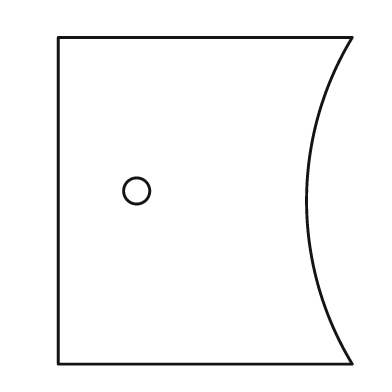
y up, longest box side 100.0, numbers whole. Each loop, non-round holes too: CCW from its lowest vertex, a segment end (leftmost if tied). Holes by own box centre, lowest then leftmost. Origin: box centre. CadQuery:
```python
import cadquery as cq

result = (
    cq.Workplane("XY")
    .moveTo(-45.0, -50.0)
    .lineTo(45.0, -50.0)
    .threePointArc((31.0, 0.0), (45.0, 50.0))
    .lineTo(-45.0, 50.0)
    .close()
    .moveTo(-21.0, 3.0)
    .circle(4.0)
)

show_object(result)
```